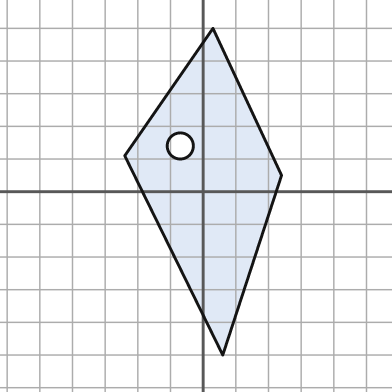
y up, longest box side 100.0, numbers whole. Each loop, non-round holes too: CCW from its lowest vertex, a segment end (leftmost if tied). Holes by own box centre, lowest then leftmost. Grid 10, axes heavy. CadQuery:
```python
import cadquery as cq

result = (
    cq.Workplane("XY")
    .moveTo(6.0, -50.0)
    .lineTo(24.0, 5.0)
    .lineTo(3.0, 50.0)
    .lineTo(-24.0, 11.0)
    .close()
    .moveTo(-7.0, 14.0)
    .circle(4.0)
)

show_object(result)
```